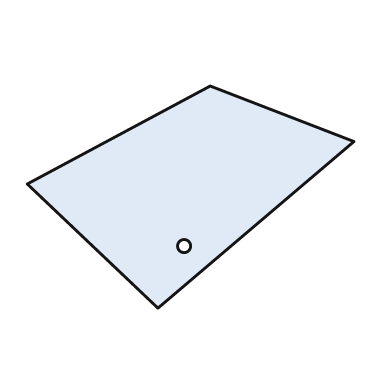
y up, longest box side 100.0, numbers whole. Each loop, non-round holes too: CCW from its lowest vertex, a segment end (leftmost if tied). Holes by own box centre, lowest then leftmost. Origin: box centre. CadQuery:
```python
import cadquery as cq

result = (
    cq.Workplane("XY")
    .moveTo(-10.0, -34.0)
    .lineTo(50.0, 17.0)
    .lineTo(6.0, 34.0)
    .lineTo(-50.0, 4.0)
    .close()
    .moveTo(-2.0, -15.0)
    .circle(2.0)
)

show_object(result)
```